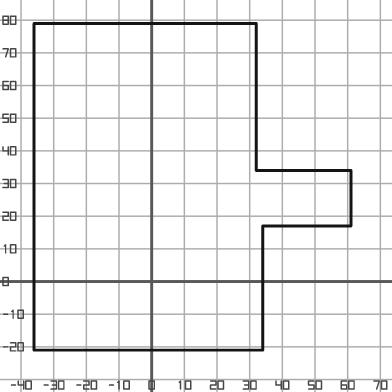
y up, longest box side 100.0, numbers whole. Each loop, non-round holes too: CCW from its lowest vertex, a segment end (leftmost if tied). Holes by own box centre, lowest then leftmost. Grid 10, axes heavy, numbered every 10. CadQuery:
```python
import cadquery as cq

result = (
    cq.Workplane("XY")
    .moveTo(-36.0, -21.0)
    .lineTo(34.0, -21.0)
    .lineTo(34.0, 17.0)
    .lineTo(61.0, 17.0)
    .lineTo(61.0, 34.0)
    .lineTo(32.0, 34.0)
    .lineTo(32.0, 79.0)
    .lineTo(-36.0, 79.0)
    .close()
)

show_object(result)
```